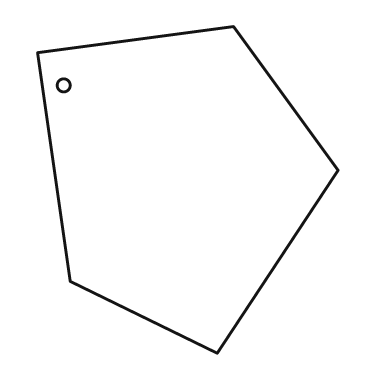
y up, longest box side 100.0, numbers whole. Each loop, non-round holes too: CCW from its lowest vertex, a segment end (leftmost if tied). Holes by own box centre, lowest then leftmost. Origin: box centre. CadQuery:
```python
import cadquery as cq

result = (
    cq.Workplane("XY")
    .moveTo(9.0, -50.0)
    .lineTo(46.0, 6.0)
    .lineTo(14.0, 50.0)
    .lineTo(-46.0, 42.0)
    .lineTo(-36.0, -28.0)
    .close()
    .moveTo(-38.0, 32.0)
    .circle(2.0)
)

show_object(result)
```